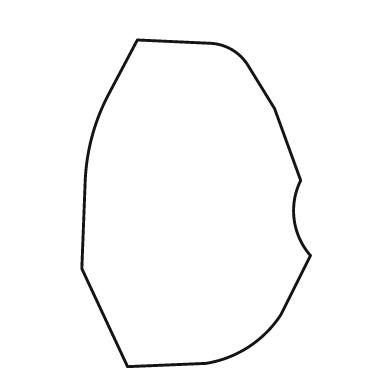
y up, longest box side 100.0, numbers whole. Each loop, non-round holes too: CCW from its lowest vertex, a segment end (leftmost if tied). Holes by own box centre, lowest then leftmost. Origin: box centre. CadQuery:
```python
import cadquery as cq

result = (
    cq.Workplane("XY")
    .moveTo(-21.0, -50.0)
    .lineTo(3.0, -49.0)
    .threePointArc((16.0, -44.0), (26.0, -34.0))
    .lineTo(35.0, -16.0)
    .threePointArc((30.0, -5.0), (32.0, 7.0))
    .lineTo(24.0, 29.0)
    .lineTo(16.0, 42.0)
    .threePointArc((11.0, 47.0), (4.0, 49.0))
    .lineTo(-18.0, 50.0)
    .lineTo(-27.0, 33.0)
    .threePointArc((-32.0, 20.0), (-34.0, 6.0))
    .lineTo(-35.0, -20.0)
    .close()
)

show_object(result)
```